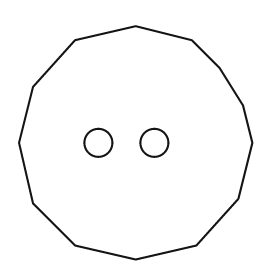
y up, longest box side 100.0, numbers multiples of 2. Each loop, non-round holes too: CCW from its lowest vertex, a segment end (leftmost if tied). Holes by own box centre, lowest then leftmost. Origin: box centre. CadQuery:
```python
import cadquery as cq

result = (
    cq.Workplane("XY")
    .moveTo(0.0, -50.0)
    .lineTo(26.0, -44.0)
    .lineTo(44.0, -24.0)
    .lineTo(50.0, 0.0)
    .lineTo(46.0, 16.0)
    .lineTo(36.0, 32.0)
    .lineTo(24.0, 44.0)
    .lineTo(0.0, 50.0)
    .lineTo(-26.0, 44.0)
    .lineTo(-44.0, 24.0)
    .lineTo(-50.0, 0.0)
    .lineTo(-44.0, -26.0)
    .lineTo(-26.0, -44.0)
    .close()
    .moveTo(-16.0, 0.0)
    .circle(6.0)
    .moveTo(8.0, 0.0)
    .circle(6.0)
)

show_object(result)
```